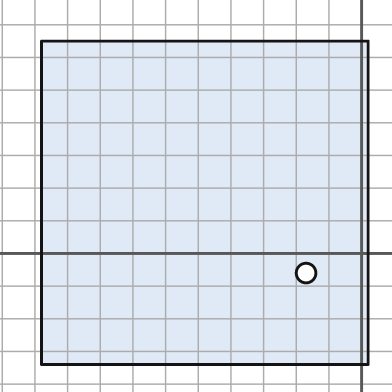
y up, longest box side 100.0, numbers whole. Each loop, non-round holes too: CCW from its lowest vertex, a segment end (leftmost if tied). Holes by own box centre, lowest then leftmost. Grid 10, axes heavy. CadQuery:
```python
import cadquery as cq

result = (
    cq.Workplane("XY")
    .moveTo(-98.0, -34.0)
    .lineTo(2.0, -34.0)
    .lineTo(2.0, 65.0)
    .lineTo(-98.0, 65.0)
    .close()
    .moveTo(-17.0, -6.0)
    .circle(3.0)
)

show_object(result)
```